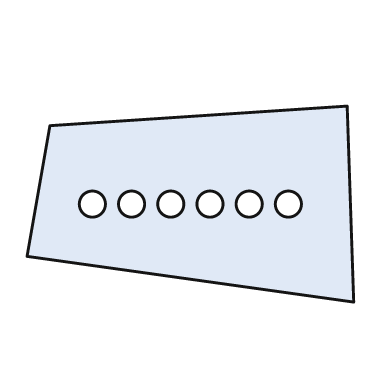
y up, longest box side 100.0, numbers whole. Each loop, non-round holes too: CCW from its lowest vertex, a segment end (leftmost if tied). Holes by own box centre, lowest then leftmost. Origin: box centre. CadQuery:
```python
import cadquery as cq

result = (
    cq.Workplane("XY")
    .moveTo(50.0, -30.0)
    .lineTo(48.0, 30.0)
    .lineTo(-43.0, 24.0)
    .lineTo(-50.0, -16.0)
    .close()
    .moveTo(-30.0, 0.0)
    .circle(4.0)
    .moveTo(-18.0, 0.0)
    .circle(4.0)
    .moveTo(-6.0, 0.0)
    .circle(4.0)
    .moveTo(6.0, 0.0)
    .circle(4.0)
    .moveTo(18.0, 0.0)
    .circle(4.0)
    .moveTo(30.0, 0.0)
    .circle(4.0)
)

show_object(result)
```